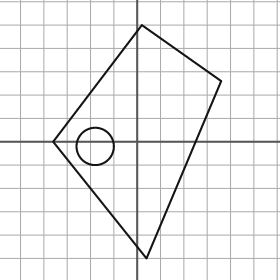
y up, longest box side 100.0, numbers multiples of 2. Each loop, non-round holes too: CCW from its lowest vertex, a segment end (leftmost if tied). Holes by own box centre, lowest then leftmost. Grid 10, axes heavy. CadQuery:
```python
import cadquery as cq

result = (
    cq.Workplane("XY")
    .moveTo(4.0, -50.0)
    .lineTo(36.0, 26.0)
    .lineTo(2.0, 50.0)
    .lineTo(-36.0, 0.0)
    .close()
    .moveTo(-18.0, -2.0)
    .circle(8.0)
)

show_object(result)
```